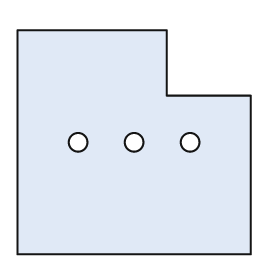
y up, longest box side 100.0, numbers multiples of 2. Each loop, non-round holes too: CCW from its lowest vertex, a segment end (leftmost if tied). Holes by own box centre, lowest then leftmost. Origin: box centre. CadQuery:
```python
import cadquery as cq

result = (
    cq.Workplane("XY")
    .moveTo(-50.0, -48.0)
    .lineTo(50.0, -48.0)
    .lineTo(50.0, 20.0)
    .lineTo(14.0, 20.0)
    .lineTo(14.0, 48.0)
    .lineTo(-50.0, 48.0)
    .close()
    .moveTo(-24.0, 0.0)
    .circle(4.0)
    .moveTo(0.0, 0.0)
    .circle(4.0)
    .moveTo(24.0, 0.0)
    .circle(4.0)
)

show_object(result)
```